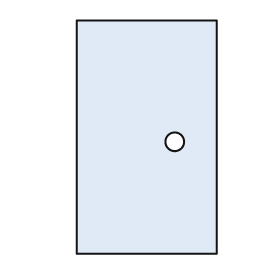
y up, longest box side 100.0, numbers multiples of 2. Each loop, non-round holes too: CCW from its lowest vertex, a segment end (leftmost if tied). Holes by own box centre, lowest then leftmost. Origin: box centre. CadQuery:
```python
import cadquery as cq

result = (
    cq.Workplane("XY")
    .moveTo(-30.0, -50.0)
    .lineTo(30.0, -50.0)
    .lineTo(30.0, 50.0)
    .lineTo(-30.0, 50.0)
    .close()
    .moveTo(12.0, -2.0)
    .circle(4.0)
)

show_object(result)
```